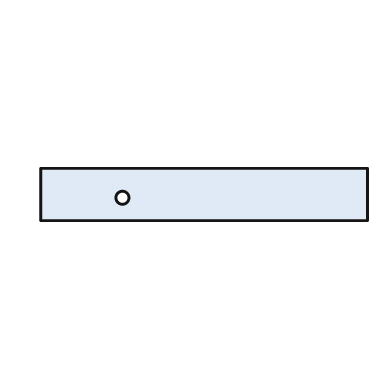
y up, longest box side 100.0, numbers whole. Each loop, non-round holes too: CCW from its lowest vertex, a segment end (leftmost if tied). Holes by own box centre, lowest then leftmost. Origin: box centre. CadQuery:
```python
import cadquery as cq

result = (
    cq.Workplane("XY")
    .moveTo(-50.0, -8.0)
    .lineTo(50.0, -8.0)
    .lineTo(50.0, 8.0)
    .lineTo(-50.0, 8.0)
    .close()
    .moveTo(-25.0, -1.0)
    .circle(2.0)
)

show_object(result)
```